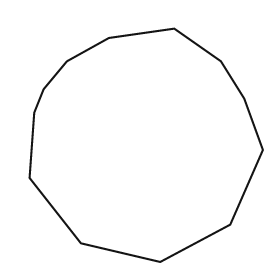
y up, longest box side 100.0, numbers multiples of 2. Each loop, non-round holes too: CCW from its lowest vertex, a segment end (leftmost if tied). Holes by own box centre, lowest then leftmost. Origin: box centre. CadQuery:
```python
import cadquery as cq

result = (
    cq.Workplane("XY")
    .moveTo(6.0, -50.0)
    .lineTo(36.0, -34.0)
    .lineTo(50.0, -2.0)
    .lineTo(42.0, 20.0)
    .lineTo(32.0, 36.0)
    .lineTo(12.0, 50.0)
    .lineTo(-16.0, 46.0)
    .lineTo(-34.0, 36.0)
    .lineTo(-44.0, 24.0)
    .lineTo(-48.0, 14.0)
    .lineTo(-50.0, -14.0)
    .lineTo(-28.0, -42.0)
    .close()
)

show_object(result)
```